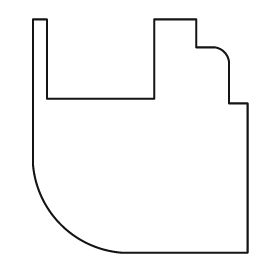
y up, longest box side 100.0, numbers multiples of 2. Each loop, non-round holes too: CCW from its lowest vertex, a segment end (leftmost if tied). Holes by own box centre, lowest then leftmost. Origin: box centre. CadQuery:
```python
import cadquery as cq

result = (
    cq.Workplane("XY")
    .moveTo(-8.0, -50.0)
    .lineTo(46.0, -50.0)
    .lineTo(46.0, 14.0)
    .lineTo(38.0, 14.0)
    .lineTo(38.0, 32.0)
    .threePointArc((36.0, 36.0), (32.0, 38.0))
    .lineTo(24.0, 38.0)
    .lineTo(24.0, 50.0)
    .lineTo(6.0, 50.0)
    .lineTo(6.0, 16.0)
    .lineTo(-40.0, 16.0)
    .lineTo(-40.0, 50.0)
    .lineTo(-46.0, 50.0)
    .lineTo(-46.0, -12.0)
    .threePointArc((-34.0, -38.0), (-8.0, -50.0))
    .close()
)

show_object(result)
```